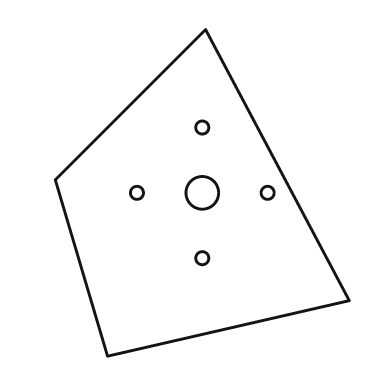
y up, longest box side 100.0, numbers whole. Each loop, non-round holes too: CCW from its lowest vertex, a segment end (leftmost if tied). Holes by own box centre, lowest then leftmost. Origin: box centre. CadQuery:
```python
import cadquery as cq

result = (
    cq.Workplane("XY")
    .moveTo(-29.0, -50.0)
    .lineTo(45.0, -33.0)
    .lineTo(1.0, 50.0)
    .lineTo(-45.0, 4.0)
    .close()
    .moveTo(0.0, -20.0)
    .circle(2.0)
    .moveTo(-20.0, 0.0)
    .circle(2.0)
    .moveTo(0.0, 0.0)
    .circle(5.0)
    .moveTo(20.0, 0.0)
    .circle(2.0)
    .moveTo(0.0, 20.0)
    .circle(2.0)
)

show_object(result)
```